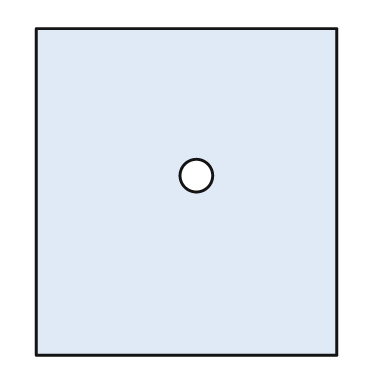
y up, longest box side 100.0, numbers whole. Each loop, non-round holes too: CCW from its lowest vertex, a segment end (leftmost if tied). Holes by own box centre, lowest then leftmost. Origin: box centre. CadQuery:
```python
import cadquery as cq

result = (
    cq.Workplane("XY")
    .moveTo(-46.0, -50.0)
    .lineTo(46.0, -50.0)
    .lineTo(46.0, 50.0)
    .lineTo(-46.0, 50.0)
    .close()
    .moveTo(3.0, 5.0)
    .circle(5.0)
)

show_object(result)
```